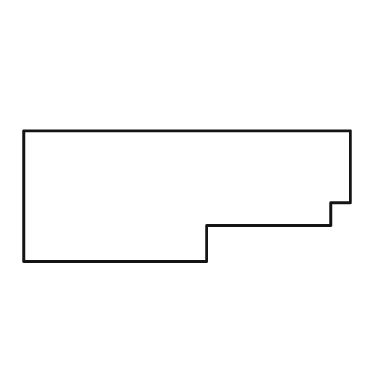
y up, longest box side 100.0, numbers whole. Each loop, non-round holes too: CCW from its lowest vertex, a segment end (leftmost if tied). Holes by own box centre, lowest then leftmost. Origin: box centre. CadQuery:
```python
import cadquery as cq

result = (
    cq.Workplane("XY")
    .moveTo(-50.0, -20.0)
    .lineTo(6.0, -20.0)
    .lineTo(6.0, -9.0)
    .lineTo(44.0, -9.0)
    .lineTo(44.0, -2.0)
    .lineTo(50.0, -2.0)
    .lineTo(50.0, 20.0)
    .lineTo(-50.0, 20.0)
    .close()
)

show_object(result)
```